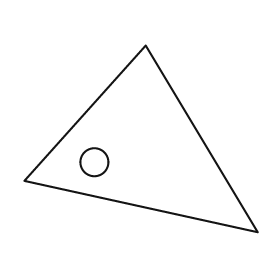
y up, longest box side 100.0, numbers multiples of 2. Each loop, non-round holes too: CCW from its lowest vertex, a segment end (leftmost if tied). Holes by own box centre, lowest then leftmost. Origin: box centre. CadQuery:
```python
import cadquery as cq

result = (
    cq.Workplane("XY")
    .moveTo(50.0, -40.0)
    .lineTo(2.0, 40.0)
    .lineTo(-50.0, -18.0)
    .close()
    .moveTo(-20.0, -10.0)
    .circle(6.0)
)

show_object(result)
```